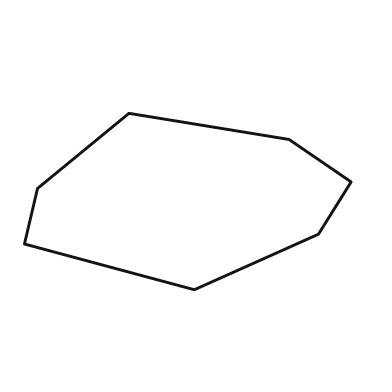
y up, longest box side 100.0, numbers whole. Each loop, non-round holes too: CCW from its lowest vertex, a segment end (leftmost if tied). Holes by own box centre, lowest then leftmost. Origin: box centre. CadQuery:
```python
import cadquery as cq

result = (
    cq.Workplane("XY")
    .moveTo(2.0, -27.0)
    .lineTo(40.0, -10.0)
    .lineTo(50.0, 6.0)
    .lineTo(31.0, 19.0)
    .lineTo(-18.0, 27.0)
    .lineTo(-46.0, 4.0)
    .lineTo(-50.0, -13.0)
    .close()
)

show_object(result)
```